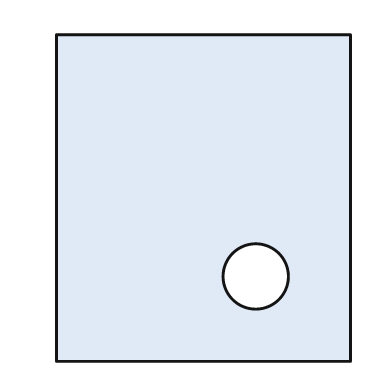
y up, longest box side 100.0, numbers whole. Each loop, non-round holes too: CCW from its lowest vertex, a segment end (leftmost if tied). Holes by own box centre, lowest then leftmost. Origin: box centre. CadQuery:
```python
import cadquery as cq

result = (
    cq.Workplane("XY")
    .moveTo(-45.0, -50.0)
    .lineTo(45.0, -50.0)
    .lineTo(45.0, 50.0)
    .lineTo(-45.0, 50.0)
    .close()
    .moveTo(16.0, -24.0)
    .circle(10.0)
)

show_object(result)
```